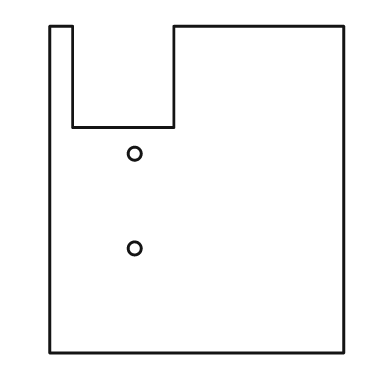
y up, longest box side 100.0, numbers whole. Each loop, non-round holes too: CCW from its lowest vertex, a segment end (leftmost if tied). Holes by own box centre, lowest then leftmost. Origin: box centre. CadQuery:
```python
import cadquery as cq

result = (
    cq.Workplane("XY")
    .moveTo(-45.0, -50.0)
    .lineTo(45.0, -50.0)
    .lineTo(45.0, 50.0)
    .lineTo(-7.0, 50.0)
    .lineTo(-7.0, 19.0)
    .lineTo(-38.0, 19.0)
    .lineTo(-38.0, 50.0)
    .lineTo(-45.0, 50.0)
    .close()
    .moveTo(-19.0, -18.0)
    .circle(2.0)
    .moveTo(-19.0, 11.0)
    .circle(2.0)
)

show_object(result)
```